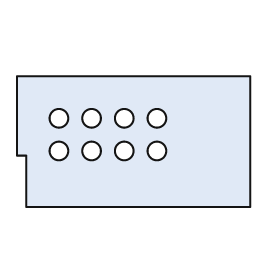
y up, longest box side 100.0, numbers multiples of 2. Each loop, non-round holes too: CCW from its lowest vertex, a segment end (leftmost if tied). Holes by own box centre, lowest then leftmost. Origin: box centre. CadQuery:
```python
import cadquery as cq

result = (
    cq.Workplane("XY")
    .moveTo(-46.0, -28.0)
    .lineTo(50.0, -28.0)
    .lineTo(50.0, 28.0)
    .lineTo(-50.0, 28.0)
    .lineTo(-50.0, -6.0)
    .lineTo(-46.0, -6.0)
    .close()
    .moveTo(-32.0, -4.0)
    .circle(4.0)
    .moveTo(-18.0, -4.0)
    .circle(4.0)
    .moveTo(-4.0, -4.0)
    .circle(4.0)
    .moveTo(10.0, -4.0)
    .circle(4.0)
    .moveTo(-32.0, 10.0)
    .circle(4.0)
    .moveTo(-18.0, 10.0)
    .circle(4.0)
    .moveTo(-4.0, 10.0)
    .circle(4.0)
    .moveTo(10.0, 10.0)
    .circle(4.0)
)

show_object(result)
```